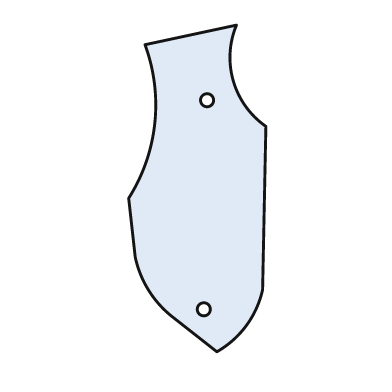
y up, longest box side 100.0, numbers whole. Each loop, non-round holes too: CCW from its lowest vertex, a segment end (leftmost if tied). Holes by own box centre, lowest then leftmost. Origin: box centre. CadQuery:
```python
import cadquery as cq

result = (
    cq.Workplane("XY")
    .moveTo(6.0, -50.0)
    .threePointArc((15.0, -42.0), (20.0, -31.0))
    .lineTo(21.0, 19.0)
    .threePointArc((11.0, 33.0), (12.0, 50.0))
    .lineTo(-16.0, 44.0)
    .threePointArc((-13.0, 20.0), (-21.0, -3.0))
    .lineTo(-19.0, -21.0)
    .threePointArc((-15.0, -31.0), (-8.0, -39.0))
    .close()
    .moveTo(2.0, -37.0)
    .circle(2.0)
    .moveTo(3.0, 27.0)
    .circle(2.0)
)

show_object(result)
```